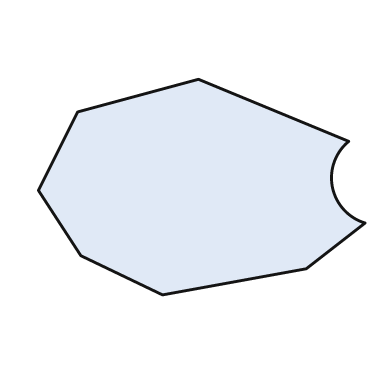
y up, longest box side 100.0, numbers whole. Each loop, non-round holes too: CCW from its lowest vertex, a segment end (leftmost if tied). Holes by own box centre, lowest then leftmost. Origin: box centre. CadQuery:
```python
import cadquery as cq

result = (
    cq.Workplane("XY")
    .moveTo(-12.0, -33.0)
    .lineTo(32.0, -25.0)
    .lineTo(50.0, -11.0)
    .threePointArc((40.0, 0.0), (45.0, 14.0))
    .lineTo(-1.0, 33.0)
    .lineTo(-38.0, 23.0)
    .lineTo(-50.0, -1.0)
    .lineTo(-37.0, -21.0)
    .close()
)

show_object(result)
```